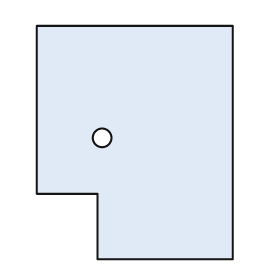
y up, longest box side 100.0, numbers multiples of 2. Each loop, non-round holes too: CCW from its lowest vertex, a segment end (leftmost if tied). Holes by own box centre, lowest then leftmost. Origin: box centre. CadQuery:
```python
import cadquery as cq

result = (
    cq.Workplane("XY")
    .moveTo(-16.0, -50.0)
    .lineTo(42.0, -50.0)
    .lineTo(42.0, 50.0)
    .lineTo(-42.0, 50.0)
    .lineTo(-42.0, -22.0)
    .lineTo(-16.0, -22.0)
    .close()
    .moveTo(-14.0, 2.0)
    .circle(4.0)
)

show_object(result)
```